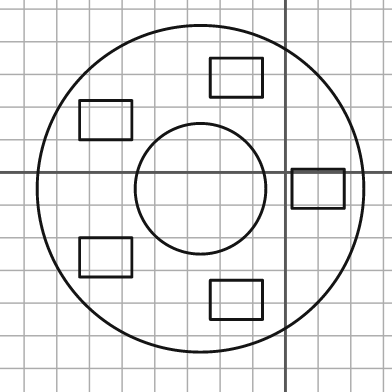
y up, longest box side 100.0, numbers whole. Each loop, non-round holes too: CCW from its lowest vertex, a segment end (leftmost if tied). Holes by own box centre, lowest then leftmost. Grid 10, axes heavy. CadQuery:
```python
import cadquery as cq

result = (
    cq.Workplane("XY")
    .moveTo(-26.0, -5.0)
    .circle(50.0)
    .moveTo(-23.0, -45.0)
    .lineTo(-7.0, -45.0)
    .lineTo(-7.0, -33.0)
    .lineTo(-23.0, -33.0)
    .close()
    .moveTo(-63.0, -32.0)
    .lineTo(-47.0, -32.0)
    .lineTo(-47.0, -20.0)
    .lineTo(-63.0, -20.0)
    .close()
    .moveTo(-26.0, -5.0)
    .circle(20.0)
    .moveTo(2.0, -11.0)
    .lineTo(18.0, -11.0)
    .lineTo(18.0, 1.0)
    .lineTo(2.0, 1.0)
    .close()
    .moveTo(-63.0, 10.0)
    .lineTo(-47.0, 10.0)
    .lineTo(-47.0, 22.0)
    .lineTo(-63.0, 22.0)
    .close()
    .moveTo(-23.0, 23.0)
    .lineTo(-7.0, 23.0)
    .lineTo(-7.0, 35.0)
    .lineTo(-23.0, 35.0)
    .close()
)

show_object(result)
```